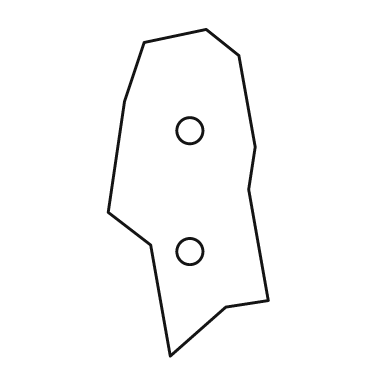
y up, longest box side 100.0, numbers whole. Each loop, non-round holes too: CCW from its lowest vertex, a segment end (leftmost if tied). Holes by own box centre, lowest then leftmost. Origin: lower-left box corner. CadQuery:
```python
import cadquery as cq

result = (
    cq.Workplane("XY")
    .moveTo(19.0, 0.0)
    .lineTo(36.0, 15.0)
    .lineTo(49.0, 17.0)
    .lineTo(43.0, 51.0)
    .lineTo(45.0, 64.0)
    .lineTo(40.0, 92.0)
    .lineTo(30.0, 100.0)
    .lineTo(11.0, 96.0)
    .lineTo(5.0, 78.0)
    .lineTo(0.0, 44.0)
    .lineTo(13.0, 34.0)
    .close()
    .moveTo(25.0, 32.0)
    .circle(4.0)
    .moveTo(25.0, 69.0)
    .circle(4.0)
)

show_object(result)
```